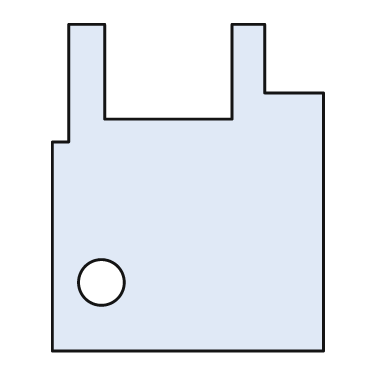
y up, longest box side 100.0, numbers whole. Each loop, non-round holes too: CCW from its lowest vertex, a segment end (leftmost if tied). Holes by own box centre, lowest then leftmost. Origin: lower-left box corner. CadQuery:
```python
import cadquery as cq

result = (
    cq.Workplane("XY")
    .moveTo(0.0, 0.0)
    .lineTo(83.0, 0.0)
    .lineTo(83.0, 79.0)
    .lineTo(65.0, 79.0)
    .lineTo(65.0, 100.0)
    .lineTo(55.0, 100.0)
    .lineTo(55.0, 71.0)
    .lineTo(16.0, 71.0)
    .lineTo(16.0, 100.0)
    .lineTo(5.0, 100.0)
    .lineTo(5.0, 64.0)
    .lineTo(0.0, 64.0)
    .close()
    .moveTo(15.0, 21.0)
    .circle(7.0)
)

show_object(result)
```